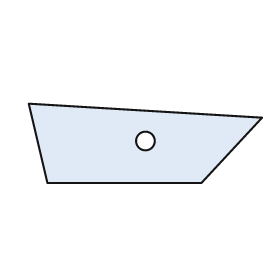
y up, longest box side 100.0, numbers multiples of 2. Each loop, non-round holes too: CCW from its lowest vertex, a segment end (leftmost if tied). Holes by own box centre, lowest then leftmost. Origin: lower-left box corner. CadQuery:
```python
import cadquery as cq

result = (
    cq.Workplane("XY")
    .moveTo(8.0, 0.0)
    .lineTo(74.0, 0.0)
    .lineTo(100.0, 28.0)
    .lineTo(0.0, 34.0)
    .close()
    .moveTo(50.0, 18.0)
    .circle(4.0)
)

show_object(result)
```